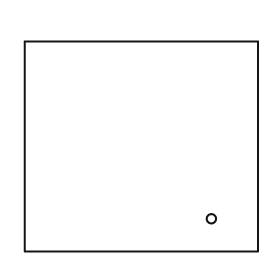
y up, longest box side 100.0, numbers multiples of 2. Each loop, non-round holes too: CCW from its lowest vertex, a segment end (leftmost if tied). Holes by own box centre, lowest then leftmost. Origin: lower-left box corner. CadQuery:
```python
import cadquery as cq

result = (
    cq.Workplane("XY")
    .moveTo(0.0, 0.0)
    .lineTo(100.0, 0.0)
    .lineTo(100.0, 90.0)
    .lineTo(0.0, 90.0)
    .close()
    .moveTo(80.0, 14.0)
    .circle(2.0)
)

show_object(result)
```